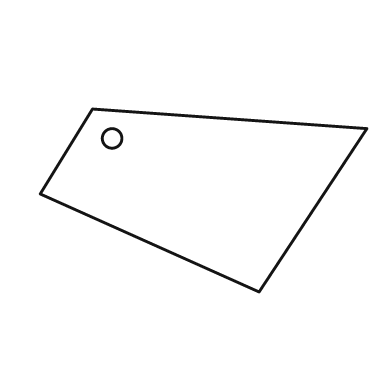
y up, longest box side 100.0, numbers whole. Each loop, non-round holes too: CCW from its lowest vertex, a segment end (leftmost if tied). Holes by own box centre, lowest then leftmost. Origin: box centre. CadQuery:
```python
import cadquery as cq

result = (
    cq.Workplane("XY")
    .moveTo(17.0, -28.0)
    .lineTo(50.0, 22.0)
    .lineTo(-34.0, 28.0)
    .lineTo(-50.0, 2.0)
    .close()
    .moveTo(-28.0, 19.0)
    .circle(3.0)
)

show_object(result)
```